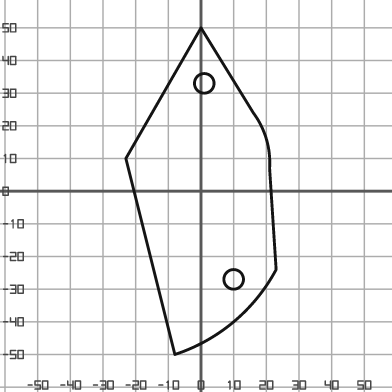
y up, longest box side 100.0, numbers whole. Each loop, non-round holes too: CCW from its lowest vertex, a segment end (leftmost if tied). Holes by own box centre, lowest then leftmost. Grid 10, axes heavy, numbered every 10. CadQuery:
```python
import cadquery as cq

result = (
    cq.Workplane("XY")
    .moveTo(-8.0, -50.0)
    .threePointArc((10.0, -40.0), (23.0, -24.0))
    .lineTo(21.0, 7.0)
    .threePointArc((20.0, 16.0), (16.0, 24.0))
    .lineTo(0.0, 50.0)
    .lineTo(-23.0, 10.0)
    .close()
    .moveTo(10.0, -27.0)
    .circle(3.0)
    .moveTo(1.0, 33.0)
    .circle(3.0)
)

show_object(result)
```